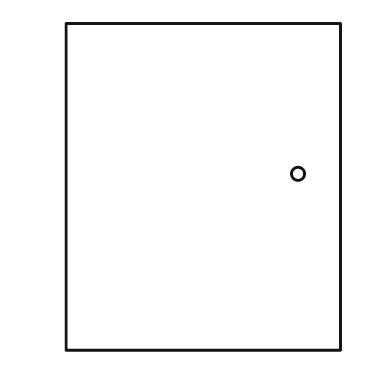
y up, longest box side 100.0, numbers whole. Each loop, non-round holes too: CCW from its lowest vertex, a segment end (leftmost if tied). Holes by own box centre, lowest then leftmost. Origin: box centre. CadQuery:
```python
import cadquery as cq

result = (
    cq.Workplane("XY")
    .moveTo(-42.0, -50.0)
    .lineTo(42.0, -50.0)
    .lineTo(42.0, 50.0)
    .lineTo(-42.0, 50.0)
    .close()
    .moveTo(29.0, 4.0)
    .circle(2.0)
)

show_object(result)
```